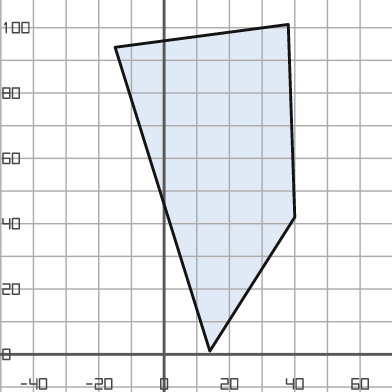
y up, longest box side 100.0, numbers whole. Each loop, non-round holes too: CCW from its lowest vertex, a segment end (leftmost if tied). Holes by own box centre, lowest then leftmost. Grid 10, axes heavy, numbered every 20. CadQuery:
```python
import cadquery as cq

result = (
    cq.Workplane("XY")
    .moveTo(14.0, 1.0)
    .lineTo(40.0, 42.0)
    .lineTo(38.0, 101.0)
    .lineTo(-15.0, 94.0)
    .close()
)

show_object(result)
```